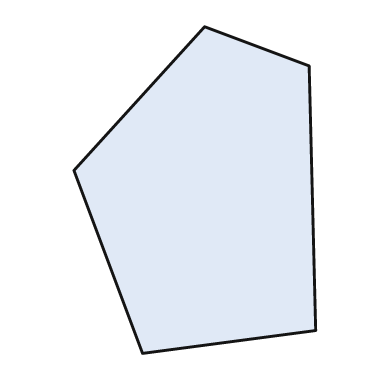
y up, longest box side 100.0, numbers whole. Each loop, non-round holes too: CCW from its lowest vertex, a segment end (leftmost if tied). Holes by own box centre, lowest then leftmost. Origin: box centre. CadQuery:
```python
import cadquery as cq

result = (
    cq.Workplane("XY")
    .moveTo(-16.0, -50.0)
    .lineTo(37.0, -43.0)
    .lineTo(35.0, 38.0)
    .lineTo(3.0, 50.0)
    .lineTo(-37.0, 6.0)
    .close()
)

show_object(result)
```